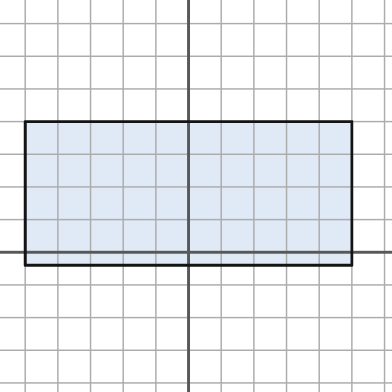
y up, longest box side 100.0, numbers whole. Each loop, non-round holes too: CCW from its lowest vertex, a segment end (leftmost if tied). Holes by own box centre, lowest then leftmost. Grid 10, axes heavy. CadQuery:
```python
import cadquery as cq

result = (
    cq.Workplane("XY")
    .moveTo(-50.0, -4.0)
    .lineTo(50.0, -4.0)
    .lineTo(50.0, 40.0)
    .lineTo(-50.0, 40.0)
    .close()
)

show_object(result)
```